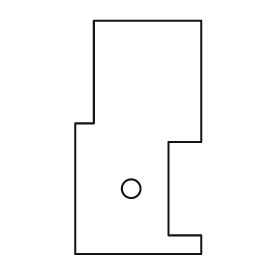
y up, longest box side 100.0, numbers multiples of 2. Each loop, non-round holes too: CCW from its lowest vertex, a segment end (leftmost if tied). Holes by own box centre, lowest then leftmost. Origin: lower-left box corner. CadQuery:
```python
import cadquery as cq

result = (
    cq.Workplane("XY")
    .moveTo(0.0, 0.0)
    .lineTo(54.0, 0.0)
    .lineTo(54.0, 8.0)
    .lineTo(40.0, 8.0)
    .lineTo(40.0, 48.0)
    .lineTo(54.0, 48.0)
    .lineTo(54.0, 100.0)
    .lineTo(8.0, 100.0)
    .lineTo(8.0, 56.0)
    .lineTo(0.0, 56.0)
    .close()
    .moveTo(24.0, 28.0)
    .circle(4.0)
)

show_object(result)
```